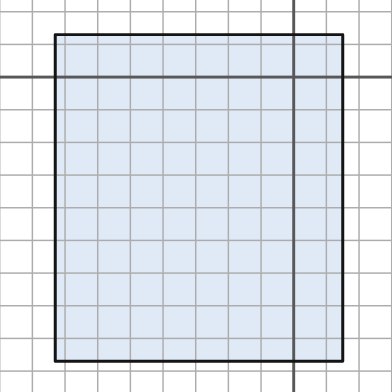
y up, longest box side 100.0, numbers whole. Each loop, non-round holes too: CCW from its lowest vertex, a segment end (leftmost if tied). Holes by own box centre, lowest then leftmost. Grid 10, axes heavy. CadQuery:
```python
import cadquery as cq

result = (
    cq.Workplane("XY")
    .moveTo(-73.0, -87.0)
    .lineTo(15.0, -87.0)
    .lineTo(15.0, 13.0)
    .lineTo(-73.0, 13.0)
    .close()
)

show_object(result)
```